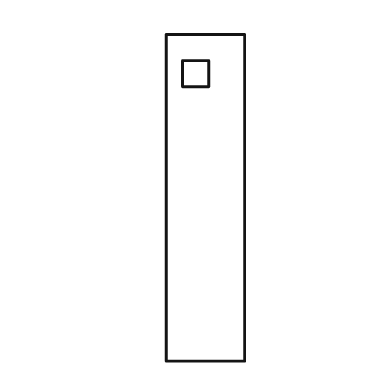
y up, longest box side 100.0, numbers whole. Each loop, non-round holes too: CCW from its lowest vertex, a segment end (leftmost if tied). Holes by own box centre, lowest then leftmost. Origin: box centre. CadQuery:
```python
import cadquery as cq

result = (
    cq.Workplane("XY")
    .moveTo(-12.0, -50.0)
    .lineTo(12.0, -50.0)
    .lineTo(12.0, 50.0)
    .lineTo(-12.0, 50.0)
    .close()
    .moveTo(-7.0, 34.0)
    .lineTo(1.0, 34.0)
    .lineTo(1.0, 42.0)
    .lineTo(-7.0, 42.0)
    .close()
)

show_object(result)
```